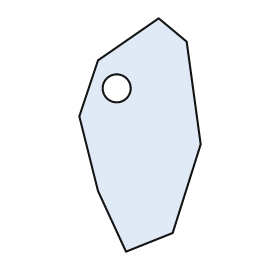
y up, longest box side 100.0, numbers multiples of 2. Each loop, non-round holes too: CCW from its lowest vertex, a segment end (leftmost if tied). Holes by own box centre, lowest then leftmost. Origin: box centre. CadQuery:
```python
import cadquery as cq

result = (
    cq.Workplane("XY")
    .moveTo(-6.0, -50.0)
    .lineTo(14.0, -42.0)
    .lineTo(26.0, -4.0)
    .lineTo(20.0, 40.0)
    .lineTo(8.0, 50.0)
    .lineTo(-18.0, 32.0)
    .lineTo(-26.0, 8.0)
    .lineTo(-18.0, -24.0)
    .close()
    .moveTo(-10.0, 20.0)
    .circle(6.0)
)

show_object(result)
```